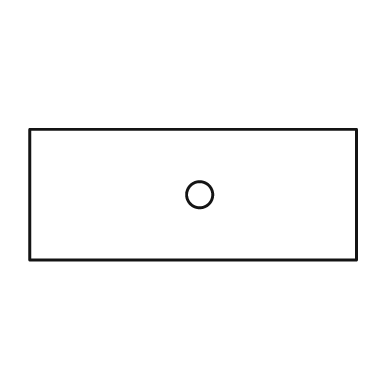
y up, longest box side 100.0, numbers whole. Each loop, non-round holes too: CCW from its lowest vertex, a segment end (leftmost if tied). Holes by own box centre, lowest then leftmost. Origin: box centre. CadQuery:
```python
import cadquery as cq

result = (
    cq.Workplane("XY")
    .moveTo(-50.0, -20.0)
    .lineTo(50.0, -20.0)
    .lineTo(50.0, 20.0)
    .lineTo(-50.0, 20.0)
    .close()
    .moveTo(2.0, 0.0)
    .circle(4.0)
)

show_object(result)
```